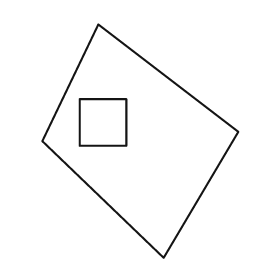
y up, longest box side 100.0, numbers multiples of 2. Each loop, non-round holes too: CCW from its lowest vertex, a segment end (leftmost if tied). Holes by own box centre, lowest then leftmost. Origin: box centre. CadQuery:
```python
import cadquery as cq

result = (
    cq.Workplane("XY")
    .moveTo(10.0, -50.0)
    .lineTo(42.0, 4.0)
    .lineTo(-18.0, 50.0)
    .lineTo(-42.0, 0.0)
    .close()
    .moveTo(-26.0, -2.0)
    .lineTo(-6.0, -2.0)
    .lineTo(-6.0, 18.0)
    .lineTo(-26.0, 18.0)
    .close()
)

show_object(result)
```